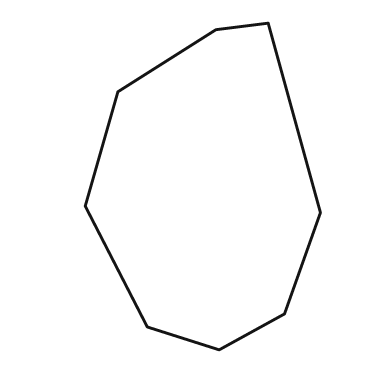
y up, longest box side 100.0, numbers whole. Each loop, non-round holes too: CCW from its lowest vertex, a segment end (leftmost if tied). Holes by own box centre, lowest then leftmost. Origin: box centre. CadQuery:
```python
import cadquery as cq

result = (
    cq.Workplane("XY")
    .moveTo(5.0, -50.0)
    .lineTo(25.0, -39.0)
    .lineTo(36.0, -8.0)
    .lineTo(20.0, 50.0)
    .lineTo(4.0, 48.0)
    .lineTo(-26.0, 29.0)
    .lineTo(-36.0, -6.0)
    .lineTo(-17.0, -43.0)
    .close()
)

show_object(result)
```